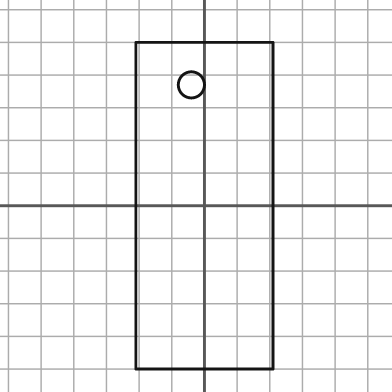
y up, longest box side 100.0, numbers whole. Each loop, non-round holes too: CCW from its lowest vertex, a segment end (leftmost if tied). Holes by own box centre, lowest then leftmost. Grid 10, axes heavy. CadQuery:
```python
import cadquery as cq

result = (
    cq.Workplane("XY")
    .moveTo(-21.0, -50.0)
    .lineTo(21.0, -50.0)
    .lineTo(21.0, 50.0)
    .lineTo(-21.0, 50.0)
    .close()
    .moveTo(-4.0, 37.0)
    .circle(4.0)
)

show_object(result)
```